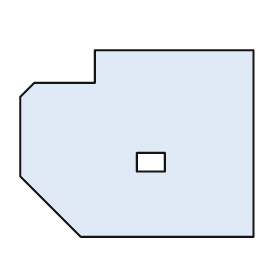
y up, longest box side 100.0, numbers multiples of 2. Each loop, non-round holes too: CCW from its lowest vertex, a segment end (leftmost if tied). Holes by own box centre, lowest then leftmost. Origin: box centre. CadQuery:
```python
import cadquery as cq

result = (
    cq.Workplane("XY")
    .moveTo(-24.0, -40.0)
    .lineTo(50.0, -40.0)
    .lineTo(50.0, 40.0)
    .lineTo(-18.0, 40.0)
    .lineTo(-18.0, 26.0)
    .lineTo(-44.0, 26.0)
    .lineTo(-50.0, 20.0)
    .lineTo(-50.0, -14.0)
    .close()
    .moveTo(0.0, -12.0)
    .lineTo(12.0, -12.0)
    .lineTo(12.0, -4.0)
    .lineTo(0.0, -4.0)
    .close()
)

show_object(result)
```